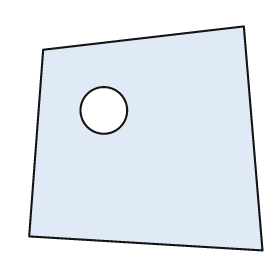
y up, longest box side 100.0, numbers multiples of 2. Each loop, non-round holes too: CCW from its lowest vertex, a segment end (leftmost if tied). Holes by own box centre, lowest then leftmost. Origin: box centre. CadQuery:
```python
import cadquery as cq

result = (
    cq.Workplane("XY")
    .moveTo(50.0, -48.0)
    .lineTo(42.0, 48.0)
    .lineTo(-44.0, 38.0)
    .lineTo(-50.0, -42.0)
    .close()
    .moveTo(-18.0, 12.0)
    .circle(10.0)
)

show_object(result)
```